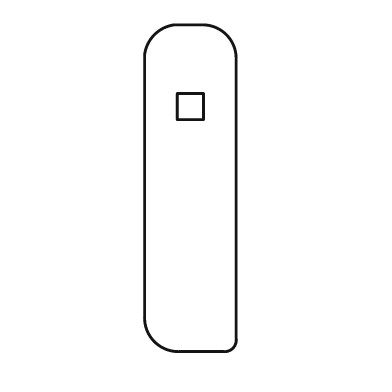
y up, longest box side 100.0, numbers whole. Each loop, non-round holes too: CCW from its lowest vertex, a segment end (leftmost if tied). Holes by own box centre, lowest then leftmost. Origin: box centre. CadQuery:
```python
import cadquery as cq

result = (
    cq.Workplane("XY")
    .moveTo(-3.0, -50.0)
    .lineTo(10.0, -50.0)
    .threePointArc((13.0, -49.0), (14.0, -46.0))
    .lineTo(14.0, 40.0)
    .threePointArc((11.0, 47.0), (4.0, 50.0))
    .lineTo(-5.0, 50.0)
    .threePointArc((-11.0, 47.0), (-14.0, 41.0))
    .lineTo(-14.0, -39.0)
    .threePointArc((-11.0, -47.0), (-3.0, -50.0))
    .close()
    .moveTo(-4.0, 21.0)
    .lineTo(4.0, 21.0)
    .lineTo(4.0, 29.0)
    .lineTo(-4.0, 29.0)
    .close()
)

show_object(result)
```